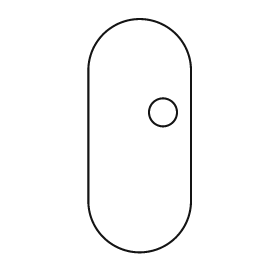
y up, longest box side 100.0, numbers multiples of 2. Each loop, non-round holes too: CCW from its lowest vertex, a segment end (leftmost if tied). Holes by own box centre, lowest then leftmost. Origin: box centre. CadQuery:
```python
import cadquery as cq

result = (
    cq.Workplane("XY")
    .moveTo(-22.0, -28.0)
    .threePointArc((0.0, -50.0), (22.0, -28.0))
    .lineTo(22.0, 28.0)
    .threePointArc((0.0, 50.0), (-22.0, 28.0))
    .close()
    .moveTo(10.0, 10.0)
    .circle(6.0)
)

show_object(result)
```